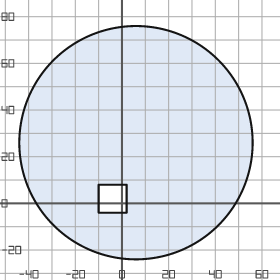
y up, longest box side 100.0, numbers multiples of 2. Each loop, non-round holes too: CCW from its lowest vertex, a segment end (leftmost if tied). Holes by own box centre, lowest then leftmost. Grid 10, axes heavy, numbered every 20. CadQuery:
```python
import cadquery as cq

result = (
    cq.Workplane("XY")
    .moveTo(6.0, 26.0)
    .circle(50.0)
    .moveTo(-10.0, -4.0)
    .lineTo(2.0, -4.0)
    .lineTo(2.0, 8.0)
    .lineTo(-10.0, 8.0)
    .close()
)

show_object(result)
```